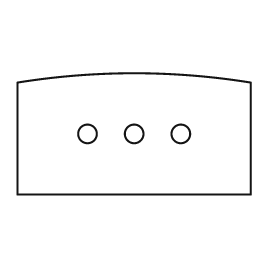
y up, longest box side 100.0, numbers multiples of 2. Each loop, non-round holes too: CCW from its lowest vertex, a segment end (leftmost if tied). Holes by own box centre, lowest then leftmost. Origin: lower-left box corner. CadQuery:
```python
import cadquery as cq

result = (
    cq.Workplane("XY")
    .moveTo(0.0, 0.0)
    .lineTo(100.0, 0.0)
    .lineTo(100.0, 48.0)
    .threePointArc((50.0, 52.0), (0.0, 48.0))
    .close()
    .moveTo(30.0, 26.0)
    .circle(4.0)
    .moveTo(50.0, 26.0)
    .circle(4.0)
    .moveTo(70.0, 26.0)
    .circle(4.0)
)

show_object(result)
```